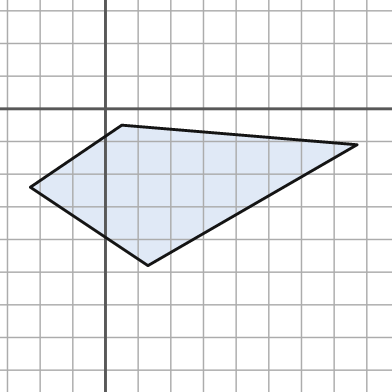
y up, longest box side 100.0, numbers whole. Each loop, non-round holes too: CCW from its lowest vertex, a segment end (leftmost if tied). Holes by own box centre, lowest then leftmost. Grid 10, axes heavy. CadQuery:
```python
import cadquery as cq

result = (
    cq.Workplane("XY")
    .moveTo(13.0, -48.0)
    .lineTo(77.0, -11.0)
    .lineTo(5.0, -5.0)
    .lineTo(-23.0, -24.0)
    .close()
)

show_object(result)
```